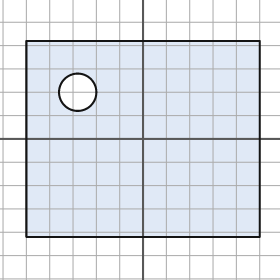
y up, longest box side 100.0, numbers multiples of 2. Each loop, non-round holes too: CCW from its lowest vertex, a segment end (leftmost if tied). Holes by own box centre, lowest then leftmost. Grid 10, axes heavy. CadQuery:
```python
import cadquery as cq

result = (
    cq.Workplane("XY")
    .moveTo(-50.0, -42.0)
    .lineTo(50.0, -42.0)
    .lineTo(50.0, 42.0)
    .lineTo(-50.0, 42.0)
    .close()
    .moveTo(-28.0, 20.0)
    .circle(8.0)
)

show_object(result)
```